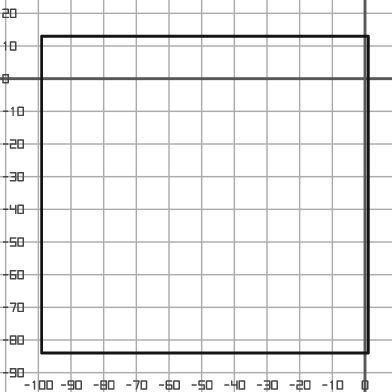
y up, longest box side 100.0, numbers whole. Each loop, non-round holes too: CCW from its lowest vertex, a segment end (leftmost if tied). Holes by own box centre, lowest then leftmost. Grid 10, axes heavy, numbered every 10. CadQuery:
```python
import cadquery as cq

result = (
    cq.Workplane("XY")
    .moveTo(-99.0, -84.0)
    .lineTo(1.0, -84.0)
    .lineTo(1.0, 13.0)
    .lineTo(-99.0, 13.0)
    .close()
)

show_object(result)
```